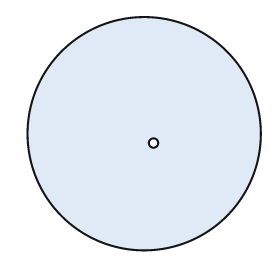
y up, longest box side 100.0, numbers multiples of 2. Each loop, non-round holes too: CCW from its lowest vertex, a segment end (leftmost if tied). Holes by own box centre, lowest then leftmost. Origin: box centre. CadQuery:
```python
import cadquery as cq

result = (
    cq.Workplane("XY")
    .moveTo(0.0, 0.0)
    .circle(50.0)
    .moveTo(4.0, -4.0)
    .circle(2.0)
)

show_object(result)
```